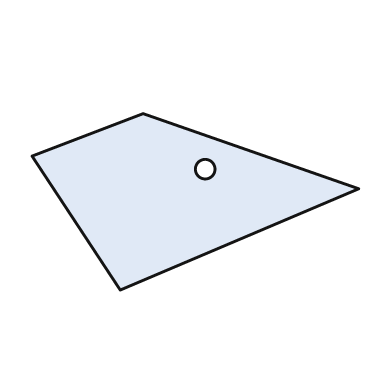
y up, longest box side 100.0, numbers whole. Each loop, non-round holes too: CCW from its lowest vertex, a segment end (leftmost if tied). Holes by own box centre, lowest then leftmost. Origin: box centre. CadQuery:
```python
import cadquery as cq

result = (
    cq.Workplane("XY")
    .moveTo(-23.0, -27.0)
    .lineTo(50.0, 4.0)
    .lineTo(-16.0, 27.0)
    .lineTo(-50.0, 14.0)
    .close()
    .moveTo(3.0, 10.0)
    .circle(3.0)
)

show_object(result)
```